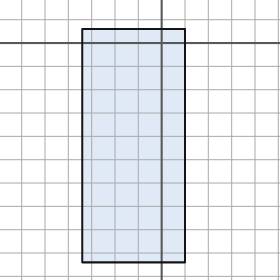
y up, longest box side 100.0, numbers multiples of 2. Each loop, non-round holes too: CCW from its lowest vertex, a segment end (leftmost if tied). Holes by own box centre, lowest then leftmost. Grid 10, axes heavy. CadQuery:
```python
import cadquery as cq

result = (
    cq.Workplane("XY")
    .moveTo(-34.0, -94.0)
    .lineTo(10.0, -94.0)
    .lineTo(10.0, 6.0)
    .lineTo(-34.0, 6.0)
    .close()
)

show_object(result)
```